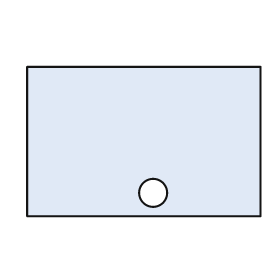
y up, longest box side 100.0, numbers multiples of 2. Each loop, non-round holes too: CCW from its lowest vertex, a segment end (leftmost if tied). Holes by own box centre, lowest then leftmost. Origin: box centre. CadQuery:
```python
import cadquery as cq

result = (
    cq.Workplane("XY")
    .moveTo(-50.0, -32.0)
    .lineTo(50.0, -32.0)
    .lineTo(50.0, 32.0)
    .lineTo(-50.0, 32.0)
    .close()
    .moveTo(4.0, -22.0)
    .circle(6.0)
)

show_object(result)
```